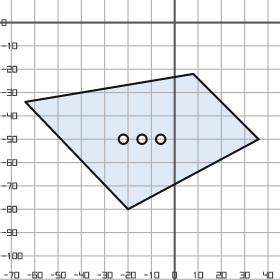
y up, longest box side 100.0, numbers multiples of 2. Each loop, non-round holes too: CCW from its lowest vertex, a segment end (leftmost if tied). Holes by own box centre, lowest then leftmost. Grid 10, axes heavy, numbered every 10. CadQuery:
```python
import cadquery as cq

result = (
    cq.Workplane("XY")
    .moveTo(-20.0, -80.0)
    .lineTo(36.0, -50.0)
    .lineTo(8.0, -22.0)
    .lineTo(-64.0, -34.0)
    .close()
    .moveTo(-22.0, -50.0)
    .circle(2.0)
    .moveTo(-14.0, -50.0)
    .circle(2.0)
    .moveTo(-6.0, -50.0)
    .circle(2.0)
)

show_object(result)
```